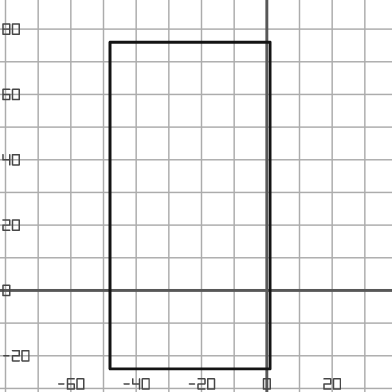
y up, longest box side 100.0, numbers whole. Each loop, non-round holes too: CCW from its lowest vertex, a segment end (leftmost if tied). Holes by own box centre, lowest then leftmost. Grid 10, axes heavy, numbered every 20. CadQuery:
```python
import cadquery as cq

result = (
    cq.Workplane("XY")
    .moveTo(-48.0, -24.0)
    .lineTo(1.0, -24.0)
    .lineTo(1.0, 76.0)
    .lineTo(-48.0, 76.0)
    .close()
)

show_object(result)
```